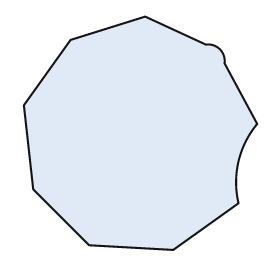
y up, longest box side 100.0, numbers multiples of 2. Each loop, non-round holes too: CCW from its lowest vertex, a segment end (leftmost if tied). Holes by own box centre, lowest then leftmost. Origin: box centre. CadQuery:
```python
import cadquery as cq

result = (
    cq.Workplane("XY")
    .moveTo(14.0, -50.0)
    .lineTo(42.0, -30.0)
    .threePointArc((42.0, -12.0), (50.0, 4.0))
    .lineTo(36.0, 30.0)
    .threePointArc((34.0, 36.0), (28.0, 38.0))
    .lineTo(2.0, 50.0)
    .lineTo(-30.0, 40.0)
    .lineTo(-50.0, 12.0)
    .lineTo(-46.0, -24.0)
    .lineTo(-22.0, -48.0)
    .close()
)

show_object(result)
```